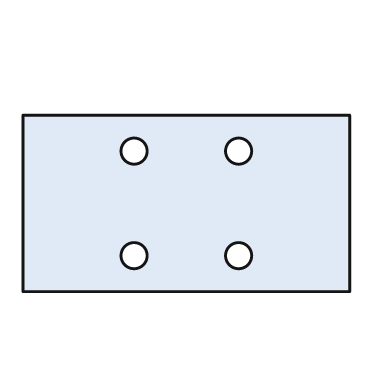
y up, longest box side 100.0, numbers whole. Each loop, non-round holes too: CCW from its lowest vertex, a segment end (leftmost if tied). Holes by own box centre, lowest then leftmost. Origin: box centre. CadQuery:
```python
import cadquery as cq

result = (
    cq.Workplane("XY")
    .moveTo(-50.0, -27.0)
    .lineTo(50.0, -27.0)
    .lineTo(50.0, 27.0)
    .lineTo(-50.0, 27.0)
    .close()
    .moveTo(-16.0, -16.0)
    .circle(4.0)
    .moveTo(16.0, -16.0)
    .circle(4.0)
    .moveTo(-16.0, 16.0)
    .circle(4.0)
    .moveTo(16.0, 16.0)
    .circle(4.0)
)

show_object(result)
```